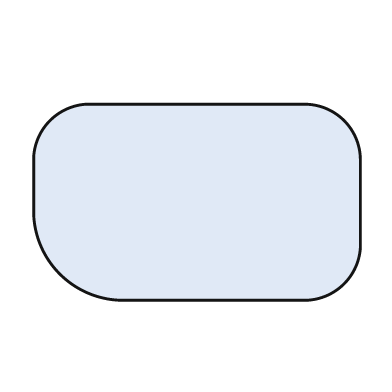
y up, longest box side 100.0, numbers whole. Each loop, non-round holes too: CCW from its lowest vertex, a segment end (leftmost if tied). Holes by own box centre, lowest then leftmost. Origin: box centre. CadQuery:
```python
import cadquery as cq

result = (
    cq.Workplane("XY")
    .moveTo(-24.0, -30.0)
    .lineTo(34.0, -30.0)
    .threePointArc((45.0, -25.0), (50.0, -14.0))
    .lineTo(50.0, 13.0)
    .threePointArc((45.0, 25.0), (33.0, 30.0))
    .lineTo(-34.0, 30.0)
    .threePointArc((-45.0, 25.0), (-50.0, 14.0))
    .lineTo(-50.0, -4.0)
    .threePointArc((-42.0, -22.0), (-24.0, -30.0))
    .close()
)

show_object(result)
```